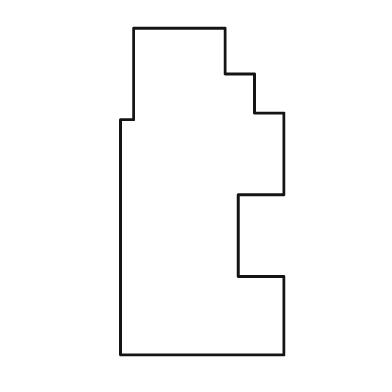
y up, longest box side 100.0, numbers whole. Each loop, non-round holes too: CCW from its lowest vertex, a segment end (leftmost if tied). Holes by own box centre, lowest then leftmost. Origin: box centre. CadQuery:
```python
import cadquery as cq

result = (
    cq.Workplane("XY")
    .moveTo(-25.0, -50.0)
    .lineTo(25.0, -50.0)
    .lineTo(25.0, -26.0)
    .lineTo(11.0, -26.0)
    .lineTo(11.0, -1.0)
    .lineTo(25.0, -1.0)
    .lineTo(25.0, 24.0)
    .lineTo(16.0, 24.0)
    .lineTo(16.0, 36.0)
    .lineTo(7.0, 36.0)
    .lineTo(7.0, 50.0)
    .lineTo(-21.0, 50.0)
    .lineTo(-21.0, 22.0)
    .lineTo(-25.0, 22.0)
    .close()
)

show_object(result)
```